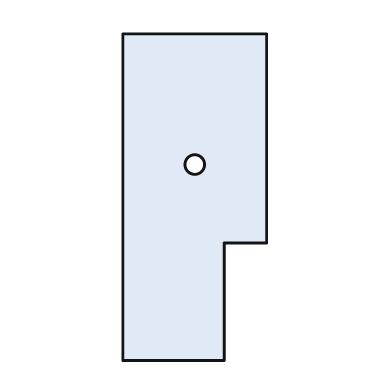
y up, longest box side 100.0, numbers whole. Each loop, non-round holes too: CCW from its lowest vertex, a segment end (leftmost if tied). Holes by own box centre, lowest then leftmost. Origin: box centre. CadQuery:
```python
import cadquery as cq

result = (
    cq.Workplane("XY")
    .moveTo(-22.0, -50.0)
    .lineTo(9.0, -50.0)
    .lineTo(9.0, -14.0)
    .lineTo(22.0, -14.0)
    .lineTo(22.0, 50.0)
    .lineTo(-22.0, 50.0)
    .close()
    .moveTo(0.0, 10.0)
    .circle(3.0)
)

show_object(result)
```